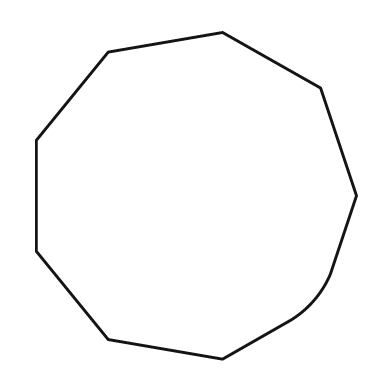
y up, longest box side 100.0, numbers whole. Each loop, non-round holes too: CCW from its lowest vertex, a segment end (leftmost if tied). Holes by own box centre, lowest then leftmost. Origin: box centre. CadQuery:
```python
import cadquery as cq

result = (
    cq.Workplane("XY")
    .moveTo(8.0, -50.0)
    .lineTo(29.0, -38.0)
    .threePointArc((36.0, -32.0), (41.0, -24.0))
    .lineTo(49.0, 0.0)
    .lineTo(38.0, 33.0)
    .lineTo(8.0, 50.0)
    .lineTo(-27.0, 44.0)
    .lineTo(-49.0, 17.0)
    .lineTo(-49.0, -17.0)
    .lineTo(-27.0, -44.0)
    .close()
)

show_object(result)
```